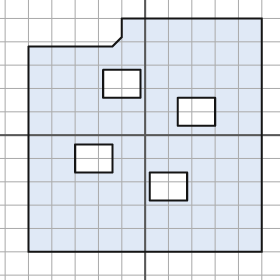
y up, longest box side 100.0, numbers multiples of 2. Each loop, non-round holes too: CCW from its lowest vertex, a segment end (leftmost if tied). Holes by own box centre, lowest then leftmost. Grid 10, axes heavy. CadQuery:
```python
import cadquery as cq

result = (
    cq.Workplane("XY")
    .moveTo(-50.0, -50.0)
    .lineTo(50.0, -50.0)
    .lineTo(50.0, 50.0)
    .lineTo(-10.0, 50.0)
    .lineTo(-10.0, 42.0)
    .lineTo(-14.0, 38.0)
    .lineTo(-50.0, 38.0)
    .close()
    .moveTo(2.0, -28.0)
    .lineTo(18.0, -28.0)
    .lineTo(18.0, -16.0)
    .lineTo(2.0, -16.0)
    .close()
    .moveTo(-30.0, -16.0)
    .lineTo(-14.0, -16.0)
    .lineTo(-14.0, -4.0)
    .lineTo(-30.0, -4.0)
    .close()
    .moveTo(14.0, 4.0)
    .lineTo(30.0, 4.0)
    .lineTo(30.0, 16.0)
    .lineTo(14.0, 16.0)
    .close()
    .moveTo(-18.0, 16.0)
    .lineTo(-2.0, 16.0)
    .lineTo(-2.0, 28.0)
    .lineTo(-18.0, 28.0)
    .close()
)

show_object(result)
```